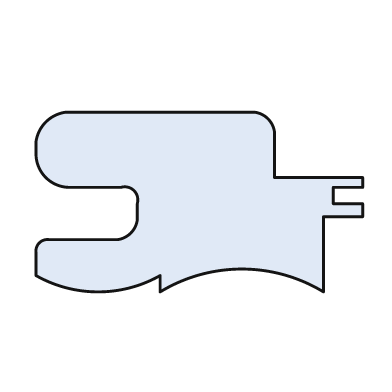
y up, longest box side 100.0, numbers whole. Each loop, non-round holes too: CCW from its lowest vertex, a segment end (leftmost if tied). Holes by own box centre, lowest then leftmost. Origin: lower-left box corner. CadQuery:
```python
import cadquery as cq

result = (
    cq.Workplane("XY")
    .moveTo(38.0, 0.0)
    .threePointArc((63.0, 7.0), (88.0, 0.0))
    .lineTo(88.0, 23.0)
    .lineTo(100.0, 23.0)
    .lineTo(100.0, 27.0)
    .lineTo(91.0, 27.0)
    .lineTo(91.0, 32.0)
    .lineTo(100.0, 32.0)
    .lineTo(100.0, 35.0)
    .lineTo(73.0, 35.0)
    .lineTo(73.0, 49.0)
    .threePointArc((71.0, 53.0), (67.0, 55.0))
    .lineTo(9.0, 55.0)
    .threePointArc((3.0, 52.0), (0.0, 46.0))
    .lineTo(0.0, 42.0)
    .threePointArc((3.0, 35.0), (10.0, 32.0))
    .lineTo(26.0, 32.0)
    .threePointArc((30.0, 31.0), (31.0, 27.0))
    .lineTo(31.0, 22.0)
    .threePointArc((29.0, 18.0), (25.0, 16.0))
    .lineTo(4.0, 16.0)
    .threePointArc((1.0, 15.0), (0.0, 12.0))
    .lineTo(0.0, 5.0)
    .threePointArc((19.0, 0.0), (38.0, 5.0))
    .close()
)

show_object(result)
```